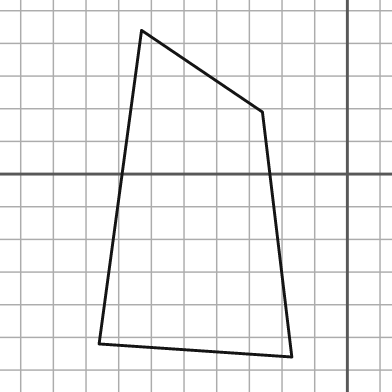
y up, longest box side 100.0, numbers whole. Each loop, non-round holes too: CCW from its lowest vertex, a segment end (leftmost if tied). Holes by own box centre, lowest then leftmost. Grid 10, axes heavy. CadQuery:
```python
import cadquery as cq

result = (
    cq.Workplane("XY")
    .moveTo(-17.0, -56.0)
    .lineTo(-26.0, 19.0)
    .lineTo(-63.0, 44.0)
    .lineTo(-76.0, -52.0)
    .close()
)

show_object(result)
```